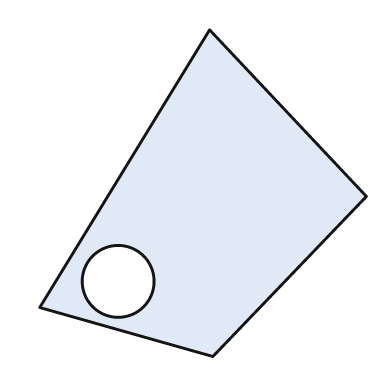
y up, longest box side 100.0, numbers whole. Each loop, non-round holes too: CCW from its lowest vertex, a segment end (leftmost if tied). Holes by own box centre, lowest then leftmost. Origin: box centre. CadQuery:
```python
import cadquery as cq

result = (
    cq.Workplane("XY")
    .moveTo(3.0, -50.0)
    .lineTo(50.0, -1.0)
    .lineTo(2.0, 50.0)
    .lineTo(-50.0, -35.0)
    .close()
    .moveTo(-26.0, -27.0)
    .circle(11.0)
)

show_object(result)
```